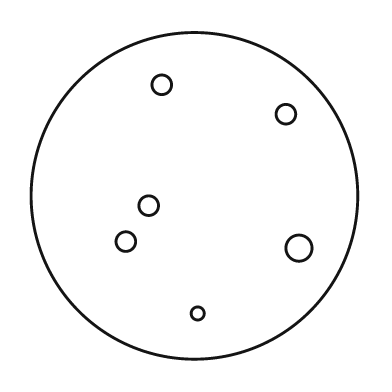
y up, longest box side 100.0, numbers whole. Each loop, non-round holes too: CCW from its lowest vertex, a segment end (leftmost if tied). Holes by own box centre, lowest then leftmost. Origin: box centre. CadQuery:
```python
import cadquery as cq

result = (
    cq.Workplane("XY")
    .moveTo(0.0, 0.0)
    .circle(50.0)
    .moveTo(1.0, -36.0)
    .circle(2.0)
    .moveTo(32.0, -16.0)
    .circle(4.0)
    .moveTo(-21.0, -14.0)
    .circle(3.0)
    .moveTo(-14.0, -3.0)
    .circle(3.0)
    .moveTo(28.0, 25.0)
    .circle(3.0)
    .moveTo(-10.0, 34.0)
    .circle(3.0)
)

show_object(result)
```